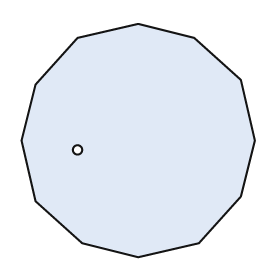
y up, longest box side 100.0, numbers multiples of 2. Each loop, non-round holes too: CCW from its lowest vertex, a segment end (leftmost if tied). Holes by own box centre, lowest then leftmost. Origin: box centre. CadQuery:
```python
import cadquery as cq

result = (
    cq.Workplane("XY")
    .moveTo(0.0, -50.0)
    .lineTo(26.0, -44.0)
    .lineTo(44.0, -24.0)
    .lineTo(50.0, 0.0)
    .lineTo(44.0, 26.0)
    .lineTo(24.0, 44.0)
    .lineTo(0.0, 50.0)
    .lineTo(-26.0, 44.0)
    .lineTo(-44.0, 24.0)
    .lineTo(-50.0, 0.0)
    .lineTo(-44.0, -26.0)
    .lineTo(-24.0, -44.0)
    .close()
    .moveTo(-26.0, -4.0)
    .circle(2.0)
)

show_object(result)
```